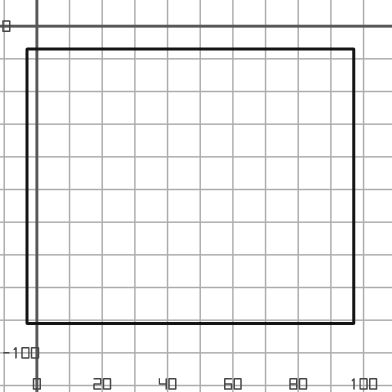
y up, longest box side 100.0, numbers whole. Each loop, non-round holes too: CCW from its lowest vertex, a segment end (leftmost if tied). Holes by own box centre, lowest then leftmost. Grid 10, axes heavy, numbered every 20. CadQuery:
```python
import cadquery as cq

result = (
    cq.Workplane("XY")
    .moveTo(-3.0, -91.0)
    .lineTo(97.0, -91.0)
    .lineTo(97.0, -7.0)
    .lineTo(-3.0, -7.0)
    .close()
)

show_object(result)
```